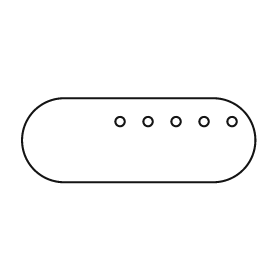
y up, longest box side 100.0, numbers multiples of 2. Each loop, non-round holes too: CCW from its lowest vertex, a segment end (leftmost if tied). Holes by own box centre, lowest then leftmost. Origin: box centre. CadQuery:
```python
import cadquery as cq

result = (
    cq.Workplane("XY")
    .moveTo(-32.0, -18.0)
    .lineTo(32.0, -18.0)
    .threePointArc((50.0, 0.0), (32.0, 18.0))
    .lineTo(-32.0, 18.0)
    .threePointArc((-50.0, 0.0), (-32.0, -18.0))
    .close()
    .moveTo(-8.0, 8.0)
    .circle(2.0)
    .moveTo(4.0, 8.0)
    .circle(2.0)
    .moveTo(16.0, 8.0)
    .circle(2.0)
    .moveTo(28.0, 8.0)
    .circle(2.0)
    .moveTo(40.0, 8.0)
    .circle(2.0)
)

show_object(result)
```